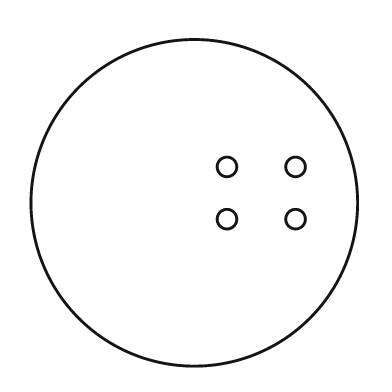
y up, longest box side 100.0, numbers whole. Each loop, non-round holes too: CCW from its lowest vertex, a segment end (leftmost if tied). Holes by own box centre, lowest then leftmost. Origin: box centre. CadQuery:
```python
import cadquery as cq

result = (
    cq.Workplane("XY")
    .moveTo(0.0, 0.0)
    .circle(50.0)
    .moveTo(10.0, -5.0)
    .circle(3.0)
    .moveTo(31.0, -5.0)
    .circle(3.0)
    .moveTo(10.0, 11.0)
    .circle(3.0)
    .moveTo(31.0, 11.0)
    .circle(3.0)
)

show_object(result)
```